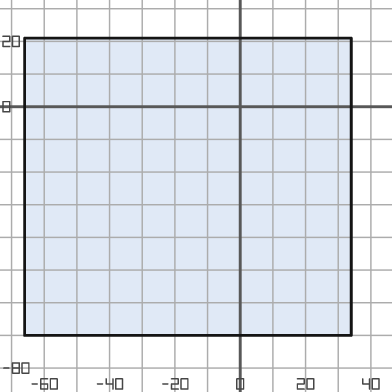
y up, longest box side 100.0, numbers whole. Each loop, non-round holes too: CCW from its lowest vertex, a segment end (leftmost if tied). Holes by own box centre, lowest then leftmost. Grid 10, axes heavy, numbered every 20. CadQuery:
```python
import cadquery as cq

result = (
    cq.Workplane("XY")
    .moveTo(-66.0, -70.0)
    .lineTo(34.0, -70.0)
    .lineTo(34.0, 21.0)
    .lineTo(-66.0, 21.0)
    .close()
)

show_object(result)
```